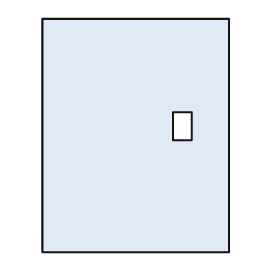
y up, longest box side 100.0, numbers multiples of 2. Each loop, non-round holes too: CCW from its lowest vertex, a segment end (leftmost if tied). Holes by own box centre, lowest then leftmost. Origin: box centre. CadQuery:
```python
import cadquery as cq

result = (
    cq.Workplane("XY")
    .moveTo(-40.0, -50.0)
    .lineTo(40.0, -50.0)
    .lineTo(40.0, 50.0)
    .lineTo(-40.0, 50.0)
    .close()
    .moveTo(16.0, -2.0)
    .lineTo(24.0, -2.0)
    .lineTo(24.0, 10.0)
    .lineTo(16.0, 10.0)
    .close()
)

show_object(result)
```